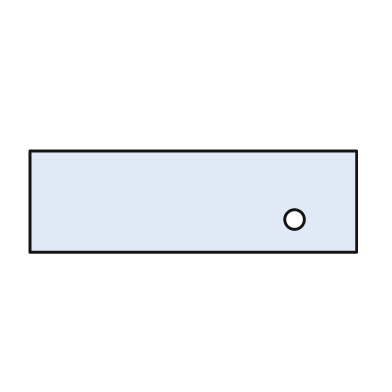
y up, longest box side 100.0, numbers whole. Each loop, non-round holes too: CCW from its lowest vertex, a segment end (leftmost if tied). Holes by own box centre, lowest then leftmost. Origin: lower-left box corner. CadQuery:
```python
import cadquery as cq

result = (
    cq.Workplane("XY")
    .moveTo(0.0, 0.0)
    .lineTo(100.0, 0.0)
    .lineTo(100.0, 31.0)
    .lineTo(0.0, 31.0)
    .close()
    .moveTo(81.0, 10.0)
    .circle(3.0)
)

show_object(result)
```